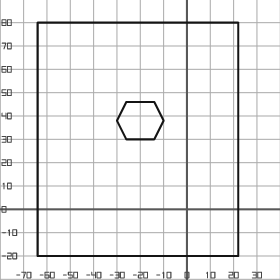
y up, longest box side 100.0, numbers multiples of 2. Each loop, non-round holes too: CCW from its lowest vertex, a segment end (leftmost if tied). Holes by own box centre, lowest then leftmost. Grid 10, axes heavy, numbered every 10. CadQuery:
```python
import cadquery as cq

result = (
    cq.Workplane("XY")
    .moveTo(-64.0, -20.0)
    .lineTo(22.0, -20.0)
    .lineTo(22.0, 80.0)
    .lineTo(-64.0, 80.0)
    .close()
    .moveTo(-26.0, 30.0)
    .lineTo(-14.0, 30.0)
    .lineTo(-10.0, 38.0)
    .lineTo(-14.0, 46.0)
    .lineTo(-26.0, 46.0)
    .lineTo(-30.0, 38.0)
    .close()
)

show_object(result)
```